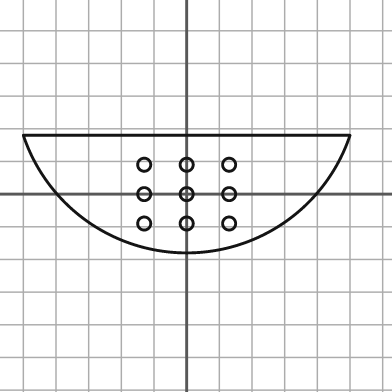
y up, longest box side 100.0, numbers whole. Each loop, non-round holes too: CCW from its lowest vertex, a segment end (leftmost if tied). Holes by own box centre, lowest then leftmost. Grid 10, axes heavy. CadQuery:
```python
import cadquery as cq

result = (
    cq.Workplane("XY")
    .moveTo(-50.0, 18.0)
    .threePointArc((0.0, -18.0), (50.0, 18.0))
    .close()
    .moveTo(-13.0, -9.0)
    .circle(2.0)
    .moveTo(0.0, -9.0)
    .circle(2.0)
    .moveTo(13.0, -9.0)
    .circle(2.0)
    .moveTo(-13.0, 0.0)
    .circle(2.0)
    .moveTo(0.0, 0.0)
    .circle(2.0)
    .moveTo(13.0, 0.0)
    .circle(2.0)
    .moveTo(-13.0, 9.0)
    .circle(2.0)
    .moveTo(0.0, 9.0)
    .circle(2.0)
    .moveTo(13.0, 9.0)
    .circle(2.0)
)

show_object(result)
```